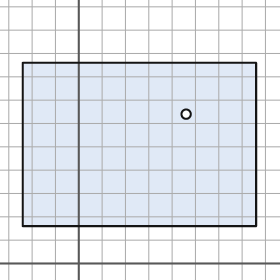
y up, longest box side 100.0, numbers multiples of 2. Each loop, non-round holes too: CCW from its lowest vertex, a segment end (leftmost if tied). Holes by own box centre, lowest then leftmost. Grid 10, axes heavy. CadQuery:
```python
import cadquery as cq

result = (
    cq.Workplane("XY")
    .moveTo(-24.0, 16.0)
    .lineTo(76.0, 16.0)
    .lineTo(76.0, 86.0)
    .lineTo(-24.0, 86.0)
    .close()
    .moveTo(46.0, 64.0)
    .circle(2.0)
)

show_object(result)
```